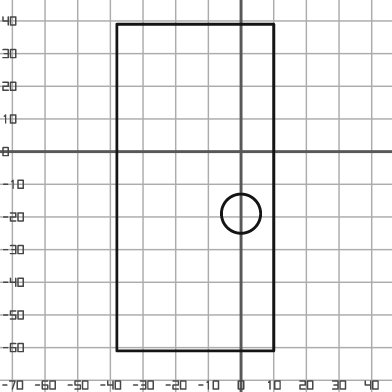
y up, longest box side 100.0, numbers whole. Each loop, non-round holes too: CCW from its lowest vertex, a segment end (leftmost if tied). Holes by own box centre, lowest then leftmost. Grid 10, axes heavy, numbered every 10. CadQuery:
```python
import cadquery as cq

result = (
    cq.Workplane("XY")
    .moveTo(-38.0, -61.0)
    .lineTo(10.0, -61.0)
    .lineTo(10.0, 39.0)
    .lineTo(-38.0, 39.0)
    .close()
    .moveTo(0.0, -19.0)
    .circle(6.0)
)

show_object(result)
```